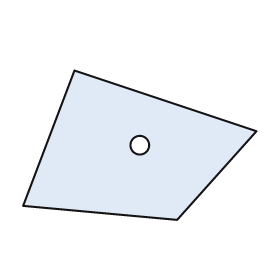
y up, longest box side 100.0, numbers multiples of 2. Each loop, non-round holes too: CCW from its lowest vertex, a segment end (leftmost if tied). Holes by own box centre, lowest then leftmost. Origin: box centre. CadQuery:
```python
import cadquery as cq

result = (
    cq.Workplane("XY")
    .moveTo(16.0, -32.0)
    .lineTo(50.0, 6.0)
    .lineTo(-28.0, 32.0)
    .lineTo(-50.0, -26.0)
    .close()
    .moveTo(0.0, 0.0)
    .circle(4.0)
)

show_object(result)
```